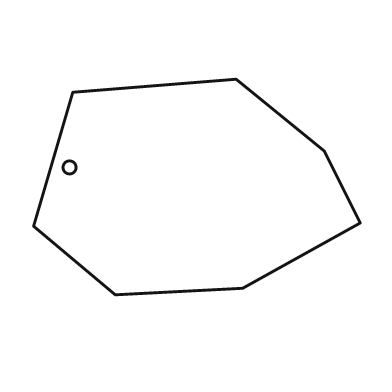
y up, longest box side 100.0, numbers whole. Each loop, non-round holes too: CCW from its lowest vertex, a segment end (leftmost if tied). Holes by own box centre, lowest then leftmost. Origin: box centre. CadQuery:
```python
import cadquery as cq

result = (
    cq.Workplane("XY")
    .moveTo(-25.0, -33.0)
    .lineTo(14.0, -31.0)
    .lineTo(50.0, -11.0)
    .lineTo(39.0, 11.0)
    .lineTo(12.0, 33.0)
    .lineTo(-38.0, 29.0)
    .lineTo(-50.0, -12.0)
    .close()
    .moveTo(-39.0, 6.0)
    .circle(2.0)
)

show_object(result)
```